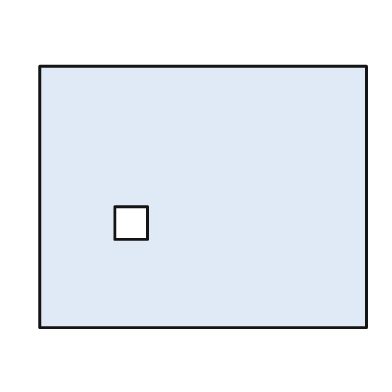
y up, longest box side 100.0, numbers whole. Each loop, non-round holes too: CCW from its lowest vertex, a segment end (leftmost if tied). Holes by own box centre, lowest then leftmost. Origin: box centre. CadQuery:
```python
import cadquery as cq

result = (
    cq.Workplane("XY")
    .moveTo(-50.0, -40.0)
    .lineTo(50.0, -40.0)
    .lineTo(50.0, 40.0)
    .lineTo(-50.0, 40.0)
    .close()
    .moveTo(-27.0, -13.0)
    .lineTo(-17.0, -13.0)
    .lineTo(-17.0, -3.0)
    .lineTo(-27.0, -3.0)
    .close()
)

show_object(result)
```